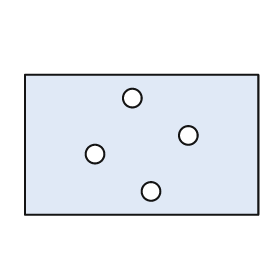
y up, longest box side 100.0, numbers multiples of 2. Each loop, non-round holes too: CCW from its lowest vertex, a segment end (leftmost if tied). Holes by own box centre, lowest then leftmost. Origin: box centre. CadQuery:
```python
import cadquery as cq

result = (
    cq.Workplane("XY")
    .moveTo(-50.0, -30.0)
    .lineTo(50.0, -30.0)
    .lineTo(50.0, 30.0)
    .lineTo(-50.0, 30.0)
    .close()
    .moveTo(4.0, -20.0)
    .circle(4.0)
    .moveTo(-20.0, -4.0)
    .circle(4.0)
    .moveTo(20.0, 4.0)
    .circle(4.0)
    .moveTo(-4.0, 20.0)
    .circle(4.0)
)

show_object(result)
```